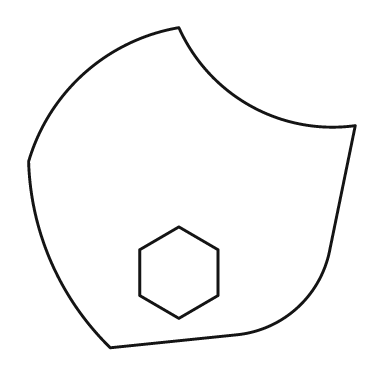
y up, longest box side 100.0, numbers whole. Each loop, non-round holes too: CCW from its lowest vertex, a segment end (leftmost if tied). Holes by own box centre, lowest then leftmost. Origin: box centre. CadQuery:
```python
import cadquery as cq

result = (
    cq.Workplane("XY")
    .moveTo(-25.0, -49.0)
    .lineTo(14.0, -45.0)
    .threePointArc((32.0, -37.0), (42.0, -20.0))
    .lineTo(50.0, 19.0)
    .threePointArc((18.0, 25.0), (-4.0, 49.0))
    .threePointArc((-33.0, 35.0), (-50.0, 8.0))
    .threePointArc((-43.0, -23.0), (-25.0, -49.0))
    .close()
    .moveTo(-4.0, -40.0)
    .lineTo(8.0, -33.0)
    .lineTo(8.0, -19.0)
    .lineTo(-4.0, -12.0)
    .lineTo(-16.0, -19.0)
    .lineTo(-16.0, -33.0)
    .close()
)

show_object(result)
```